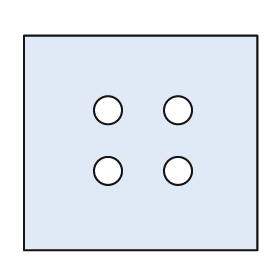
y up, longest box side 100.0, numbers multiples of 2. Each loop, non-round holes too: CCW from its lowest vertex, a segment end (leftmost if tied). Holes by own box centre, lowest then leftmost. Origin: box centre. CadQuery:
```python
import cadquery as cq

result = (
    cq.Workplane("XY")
    .moveTo(-50.0, -46.0)
    .lineTo(50.0, -46.0)
    .lineTo(50.0, 46.0)
    .lineTo(-50.0, 46.0)
    .close()
    .moveTo(-14.0, -12.0)
    .circle(6.0)
    .moveTo(16.0, -12.0)
    .circle(6.0)
    .moveTo(-14.0, 14.0)
    .circle(6.0)
    .moveTo(16.0, 14.0)
    .circle(6.0)
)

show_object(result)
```